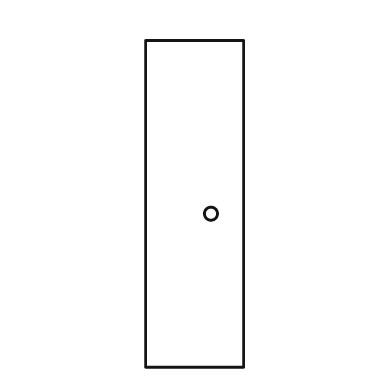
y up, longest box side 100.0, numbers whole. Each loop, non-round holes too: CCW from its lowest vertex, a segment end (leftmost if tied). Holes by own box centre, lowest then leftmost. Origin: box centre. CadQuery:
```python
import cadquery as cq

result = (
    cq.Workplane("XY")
    .moveTo(-15.0, -50.0)
    .lineTo(15.0, -50.0)
    .lineTo(15.0, 50.0)
    .lineTo(-15.0, 50.0)
    .close()
    .moveTo(5.0, -3.0)
    .circle(2.0)
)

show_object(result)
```